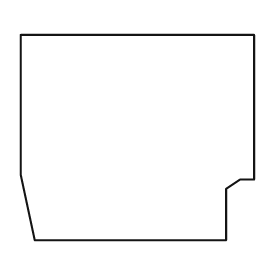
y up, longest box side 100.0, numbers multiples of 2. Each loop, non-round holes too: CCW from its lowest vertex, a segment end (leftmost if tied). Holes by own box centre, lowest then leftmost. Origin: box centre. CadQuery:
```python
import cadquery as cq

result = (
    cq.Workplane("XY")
    .moveTo(-44.0, -44.0)
    .lineTo(38.0, -44.0)
    .lineTo(38.0, -22.0)
    .lineTo(44.0, -18.0)
    .lineTo(50.0, -18.0)
    .lineTo(50.0, 44.0)
    .lineTo(-50.0, 44.0)
    .lineTo(-50.0, -16.0)
    .close()
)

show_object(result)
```